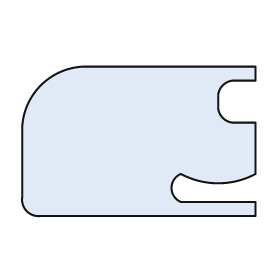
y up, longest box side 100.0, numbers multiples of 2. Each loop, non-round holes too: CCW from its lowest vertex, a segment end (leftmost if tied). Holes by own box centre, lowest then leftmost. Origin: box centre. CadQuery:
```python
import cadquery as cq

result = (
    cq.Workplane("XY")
    .moveTo(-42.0, -32.0)
    .lineTo(50.0, -32.0)
    .lineTo(50.0, -26.0)
    .lineTo(18.0, -26.0)
    .threePointArc((14.0, -20.0), (18.0, -14.0))
    .threePointArc((34.0, -18.0), (50.0, -14.0))
    .lineTo(50.0, 8.0)
    .lineTo(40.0, 8.0)
    .threePointArc((36.0, 10.0), (34.0, 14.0))
    .lineTo(34.0, 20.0)
    .threePointArc((36.0, 24.0), (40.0, 26.0))
    .lineTo(50.0, 26.0)
    .lineTo(50.0, 32.0)
    .lineTo(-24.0, 32.0)
    .threePointArc((-42.0, 24.0), (-50.0, 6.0))
    .lineTo(-50.0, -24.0)
    .threePointArc((-48.0, -30.0), (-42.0, -32.0))
    .close()
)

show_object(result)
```